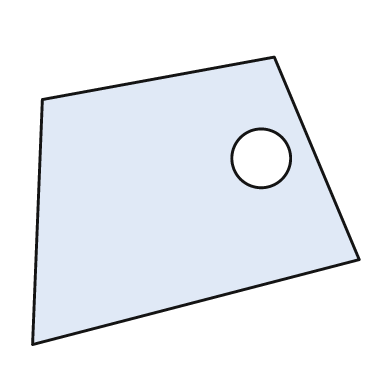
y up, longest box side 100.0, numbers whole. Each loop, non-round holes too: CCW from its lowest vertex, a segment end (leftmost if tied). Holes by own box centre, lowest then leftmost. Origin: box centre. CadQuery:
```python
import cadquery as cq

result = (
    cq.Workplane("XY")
    .moveTo(-50.0, -44.0)
    .lineTo(50.0, -18.0)
    .lineTo(24.0, 44.0)
    .lineTo(-47.0, 31.0)
    .close()
    .moveTo(20.0, 13.0)
    .circle(9.0)
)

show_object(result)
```